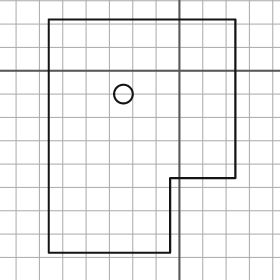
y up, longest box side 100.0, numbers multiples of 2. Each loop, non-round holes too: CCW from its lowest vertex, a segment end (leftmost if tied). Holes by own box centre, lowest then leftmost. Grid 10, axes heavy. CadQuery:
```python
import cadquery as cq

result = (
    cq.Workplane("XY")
    .moveTo(-56.0, -78.0)
    .lineTo(-4.0, -78.0)
    .lineTo(-4.0, -46.0)
    .lineTo(24.0, -46.0)
    .lineTo(24.0, 22.0)
    .lineTo(-56.0, 22.0)
    .close()
    .moveTo(-24.0, -10.0)
    .circle(4.0)
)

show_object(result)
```